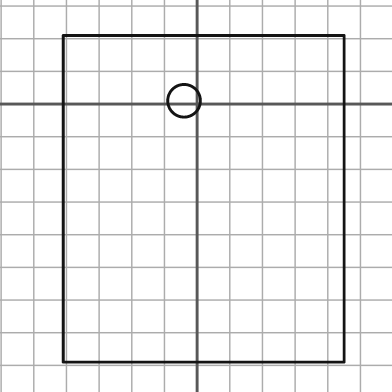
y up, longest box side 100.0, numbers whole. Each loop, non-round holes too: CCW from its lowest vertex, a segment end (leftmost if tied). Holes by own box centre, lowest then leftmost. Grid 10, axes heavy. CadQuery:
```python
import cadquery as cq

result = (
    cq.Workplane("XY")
    .moveTo(-41.0, -79.0)
    .lineTo(45.0, -79.0)
    .lineTo(45.0, 21.0)
    .lineTo(-41.0, 21.0)
    .close()
    .moveTo(-4.0, 1.0)
    .circle(5.0)
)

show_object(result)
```